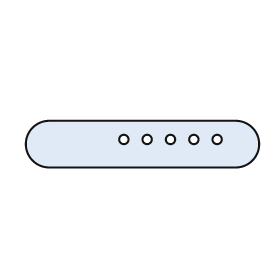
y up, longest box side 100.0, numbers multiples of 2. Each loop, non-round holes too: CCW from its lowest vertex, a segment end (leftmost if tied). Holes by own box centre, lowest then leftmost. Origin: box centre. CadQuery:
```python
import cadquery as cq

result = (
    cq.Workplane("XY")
    .moveTo(-40.0, -10.0)
    .lineTo(40.0, -10.0)
    .threePointArc((50.0, 0.0), (40.0, 10.0))
    .lineTo(-40.0, 10.0)
    .threePointArc((-50.0, 0.0), (-40.0, -10.0))
    .close()
    .moveTo(-8.0, 2.0)
    .circle(2.0)
    .moveTo(2.0, 2.0)
    .circle(2.0)
    .moveTo(12.0, 2.0)
    .circle(2.0)
    .moveTo(22.0, 2.0)
    .circle(2.0)
    .moveTo(32.0, 2.0)
    .circle(2.0)
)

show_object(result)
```